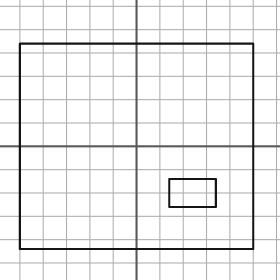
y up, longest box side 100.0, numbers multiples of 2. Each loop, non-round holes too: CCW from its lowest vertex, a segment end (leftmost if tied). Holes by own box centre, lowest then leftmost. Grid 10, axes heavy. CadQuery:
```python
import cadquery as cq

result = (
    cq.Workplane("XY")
    .moveTo(-50.0, -44.0)
    .lineTo(50.0, -44.0)
    .lineTo(50.0, 44.0)
    .lineTo(-50.0, 44.0)
    .close()
    .moveTo(14.0, -26.0)
    .lineTo(34.0, -26.0)
    .lineTo(34.0, -14.0)
    .lineTo(14.0, -14.0)
    .close()
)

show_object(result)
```